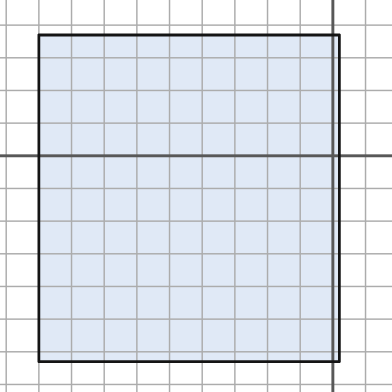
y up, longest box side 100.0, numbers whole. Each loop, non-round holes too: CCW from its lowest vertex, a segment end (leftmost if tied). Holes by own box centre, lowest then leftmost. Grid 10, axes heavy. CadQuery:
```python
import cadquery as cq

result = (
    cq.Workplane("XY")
    .moveTo(-90.0, -63.0)
    .lineTo(2.0, -63.0)
    .lineTo(2.0, 37.0)
    .lineTo(-90.0, 37.0)
    .close()
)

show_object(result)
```